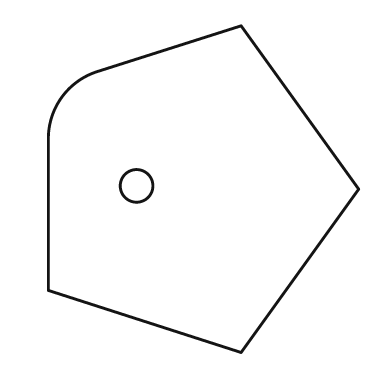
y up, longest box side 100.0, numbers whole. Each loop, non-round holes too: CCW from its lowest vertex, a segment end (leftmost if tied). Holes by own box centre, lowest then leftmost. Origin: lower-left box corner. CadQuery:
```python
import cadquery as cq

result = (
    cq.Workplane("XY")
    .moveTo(59.0, 0.0)
    .lineTo(95.0, 50.0)
    .lineTo(59.0, 100.0)
    .lineTo(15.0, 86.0)
    .threePointArc((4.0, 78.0), (0.0, 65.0))
    .lineTo(0.0, 19.0)
    .close()
    .moveTo(27.0, 51.0)
    .circle(5.0)
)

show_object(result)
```